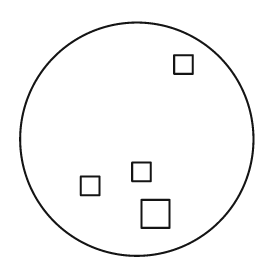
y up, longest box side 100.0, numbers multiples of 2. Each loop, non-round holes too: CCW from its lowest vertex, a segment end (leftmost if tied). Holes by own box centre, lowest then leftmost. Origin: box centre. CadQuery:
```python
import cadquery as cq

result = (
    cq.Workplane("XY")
    .moveTo(0.0, 0.0)
    .circle(50.0)
    .moveTo(2.0, -38.0)
    .lineTo(14.0, -38.0)
    .lineTo(14.0, -26.0)
    .lineTo(2.0, -26.0)
    .close()
    .moveTo(-24.0, -24.0)
    .lineTo(-16.0, -24.0)
    .lineTo(-16.0, -16.0)
    .lineTo(-24.0, -16.0)
    .close()
    .moveTo(-2.0, -18.0)
    .lineTo(6.0, -18.0)
    .lineTo(6.0, -10.0)
    .lineTo(-2.0, -10.0)
    .close()
    .moveTo(16.0, 28.0)
    .lineTo(24.0, 28.0)
    .lineTo(24.0, 36.0)
    .lineTo(16.0, 36.0)
    .close()
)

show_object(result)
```